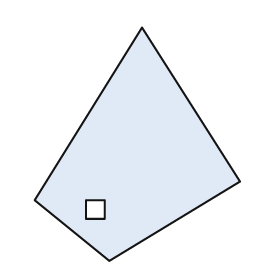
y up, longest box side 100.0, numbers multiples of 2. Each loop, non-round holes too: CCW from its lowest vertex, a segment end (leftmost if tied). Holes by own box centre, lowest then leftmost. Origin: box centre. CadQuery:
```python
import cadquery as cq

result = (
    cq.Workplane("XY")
    .moveTo(-12.0, -50.0)
    .lineTo(44.0, -16.0)
    .lineTo(2.0, 50.0)
    .lineTo(-44.0, -24.0)
    .close()
    .moveTo(-22.0, -32.0)
    .lineTo(-14.0, -32.0)
    .lineTo(-14.0, -24.0)
    .lineTo(-22.0, -24.0)
    .close()
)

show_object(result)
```